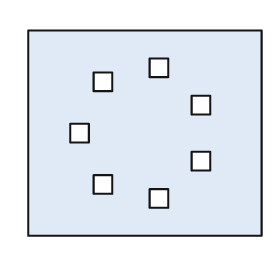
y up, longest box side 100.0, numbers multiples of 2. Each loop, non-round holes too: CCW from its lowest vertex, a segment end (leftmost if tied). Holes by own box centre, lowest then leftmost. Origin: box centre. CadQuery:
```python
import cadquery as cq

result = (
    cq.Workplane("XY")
    .moveTo(-50.0, -44.0)
    .lineTo(50.0, -44.0)
    .lineTo(50.0, 44.0)
    .lineTo(-50.0, 44.0)
    .close()
    .moveTo(2.0, -32.0)
    .lineTo(10.0, -32.0)
    .lineTo(10.0, -24.0)
    .lineTo(2.0, -24.0)
    .close()
    .moveTo(-22.0, -26.0)
    .lineTo(-14.0, -26.0)
    .lineTo(-14.0, -18.0)
    .lineTo(-22.0, -18.0)
    .close()
    .moveTo(20.0, -16.0)
    .lineTo(28.0, -16.0)
    .lineTo(28.0, -8.0)
    .lineTo(20.0, -8.0)
    .close()
    .moveTo(-32.0, -4.0)
    .lineTo(-24.0, -4.0)
    .lineTo(-24.0, 4.0)
    .lineTo(-32.0, 4.0)
    .close()
    .moveTo(20.0, 8.0)
    .lineTo(28.0, 8.0)
    .lineTo(28.0, 16.0)
    .lineTo(20.0, 16.0)
    .close()
    .moveTo(-22.0, 18.0)
    .lineTo(-14.0, 18.0)
    .lineTo(-14.0, 26.0)
    .lineTo(-22.0, 26.0)
    .close()
    .moveTo(2.0, 24.0)
    .lineTo(10.0, 24.0)
    .lineTo(10.0, 32.0)
    .lineTo(2.0, 32.0)
    .close()
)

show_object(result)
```